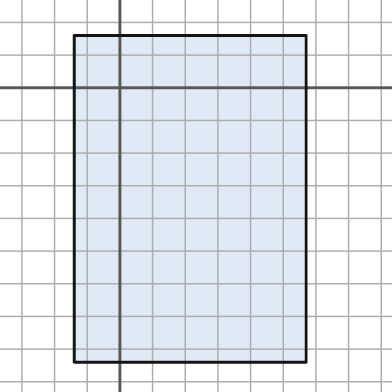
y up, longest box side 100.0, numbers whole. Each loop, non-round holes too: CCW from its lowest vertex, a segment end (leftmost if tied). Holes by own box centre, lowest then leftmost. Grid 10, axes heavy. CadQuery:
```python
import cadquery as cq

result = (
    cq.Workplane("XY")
    .moveTo(-14.0, -84.0)
    .lineTo(57.0, -84.0)
    .lineTo(57.0, 16.0)
    .lineTo(-14.0, 16.0)
    .close()
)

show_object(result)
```